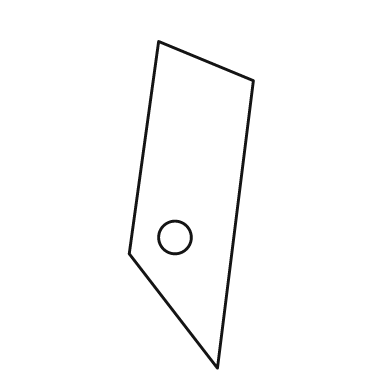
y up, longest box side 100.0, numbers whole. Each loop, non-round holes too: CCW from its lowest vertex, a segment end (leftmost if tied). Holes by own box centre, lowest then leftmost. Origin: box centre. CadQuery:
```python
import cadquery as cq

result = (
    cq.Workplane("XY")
    .moveTo(8.0, -50.0)
    .lineTo(19.0, 38.0)
    .lineTo(-10.0, 50.0)
    .lineTo(-19.0, -15.0)
    .close()
    .moveTo(-5.0, -10.0)
    .circle(5.0)
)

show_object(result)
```